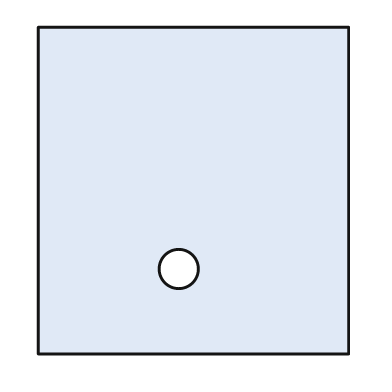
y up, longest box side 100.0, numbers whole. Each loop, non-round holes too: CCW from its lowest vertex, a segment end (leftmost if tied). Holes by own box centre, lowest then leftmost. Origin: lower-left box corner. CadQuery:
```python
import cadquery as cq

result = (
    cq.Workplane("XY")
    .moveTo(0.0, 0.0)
    .lineTo(95.0, 0.0)
    .lineTo(95.0, 100.0)
    .lineTo(0.0, 100.0)
    .close()
    .moveTo(43.0, 26.0)
    .circle(6.0)
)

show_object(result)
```